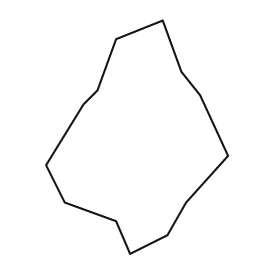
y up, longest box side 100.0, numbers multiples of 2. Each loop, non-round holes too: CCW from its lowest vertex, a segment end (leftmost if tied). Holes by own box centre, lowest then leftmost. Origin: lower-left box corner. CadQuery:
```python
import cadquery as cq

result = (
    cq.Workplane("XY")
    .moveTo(36.0, 0.0)
    .lineTo(52.0, 8.0)
    .lineTo(60.0, 22.0)
    .lineTo(78.0, 42.0)
    .lineTo(66.0, 68.0)
    .lineTo(58.0, 78.0)
    .lineTo(50.0, 100.0)
    .lineTo(30.0, 92.0)
    .lineTo(22.0, 70.0)
    .lineTo(16.0, 64.0)
    .lineTo(0.0, 38.0)
    .lineTo(8.0, 22.0)
    .lineTo(30.0, 14.0)
    .close()
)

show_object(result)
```